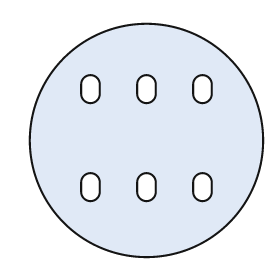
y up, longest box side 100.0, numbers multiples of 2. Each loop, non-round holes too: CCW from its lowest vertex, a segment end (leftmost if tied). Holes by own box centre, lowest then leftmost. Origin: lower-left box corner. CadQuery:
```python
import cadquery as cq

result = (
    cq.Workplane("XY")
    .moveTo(50.0, 50.0)
    .circle(50.0)
    .moveTo(22.0, 28.0)
    .threePointArc((26.0, 24.0), (30.0, 28.0))
    .lineTo(30.0, 32.0)
    .threePointArc((26.0, 36.0), (22.0, 32.0))
    .close()
    .moveTo(46.0, 28.0)
    .threePointArc((50.0, 24.0), (54.0, 28.0))
    .lineTo(54.0, 32.0)
    .threePointArc((50.0, 36.0), (46.0, 32.0))
    .close()
    .moveTo(70.0, 28.0)
    .threePointArc((74.0, 24.0), (78.0, 28.0))
    .lineTo(78.0, 32.0)
    .threePointArc((74.0, 36.0), (70.0, 32.0))
    .close()
    .moveTo(22.0, 70.0)
    .threePointArc((26.0, 66.0), (30.0, 70.0))
    .lineTo(30.0, 74.0)
    .threePointArc((26.0, 78.0), (22.0, 74.0))
    .close()
    .moveTo(46.0, 70.0)
    .threePointArc((50.0, 66.0), (54.0, 70.0))
    .lineTo(54.0, 74.0)
    .threePointArc((50.0, 78.0), (46.0, 74.0))
    .close()
    .moveTo(70.0, 70.0)
    .threePointArc((74.0, 66.0), (78.0, 70.0))
    .lineTo(78.0, 74.0)
    .threePointArc((74.0, 78.0), (70.0, 74.0))
    .close()
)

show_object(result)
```